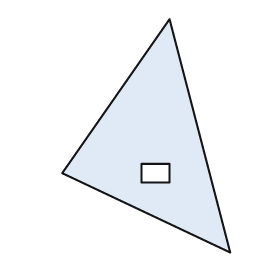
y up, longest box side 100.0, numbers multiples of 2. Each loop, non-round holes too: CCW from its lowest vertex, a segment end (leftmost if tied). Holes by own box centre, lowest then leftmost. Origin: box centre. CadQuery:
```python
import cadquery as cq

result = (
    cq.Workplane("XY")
    .moveTo(36.0, -50.0)
    .lineTo(10.0, 50.0)
    .lineTo(-36.0, -16.0)
    .close()
    .moveTo(-2.0, -20.0)
    .lineTo(10.0, -20.0)
    .lineTo(10.0, -12.0)
    .lineTo(-2.0, -12.0)
    .close()
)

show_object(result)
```